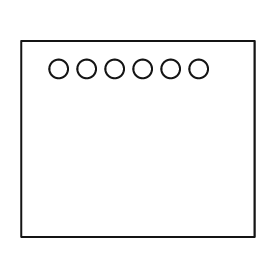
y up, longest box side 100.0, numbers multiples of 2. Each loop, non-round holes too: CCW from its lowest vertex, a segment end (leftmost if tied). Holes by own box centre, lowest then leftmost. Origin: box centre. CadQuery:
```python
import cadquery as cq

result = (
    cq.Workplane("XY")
    .moveTo(-50.0, -42.0)
    .lineTo(50.0, -42.0)
    .lineTo(50.0, 42.0)
    .lineTo(-50.0, 42.0)
    .close()
    .moveTo(-34.0, 30.0)
    .circle(4.0)
    .moveTo(-22.0, 30.0)
    .circle(4.0)
    .moveTo(-10.0, 30.0)
    .circle(4.0)
    .moveTo(2.0, 30.0)
    .circle(4.0)
    .moveTo(14.0, 30.0)
    .circle(4.0)
    .moveTo(26.0, 30.0)
    .circle(4.0)
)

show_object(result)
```